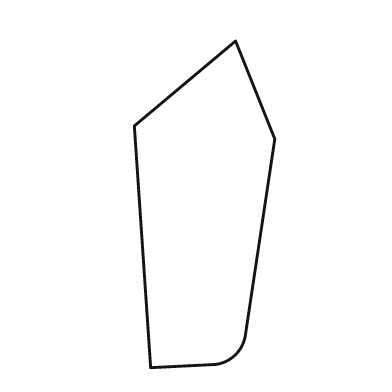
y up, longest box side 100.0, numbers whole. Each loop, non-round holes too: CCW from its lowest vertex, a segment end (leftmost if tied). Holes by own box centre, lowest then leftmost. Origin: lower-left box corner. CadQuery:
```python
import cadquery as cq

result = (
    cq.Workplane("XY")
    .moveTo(5.0, 0.0)
    .lineTo(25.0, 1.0)
    .threePointArc((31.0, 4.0), (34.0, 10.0))
    .lineTo(43.0, 70.0)
    .lineTo(31.0, 100.0)
    .lineTo(0.0, 74.0)
    .close()
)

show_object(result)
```